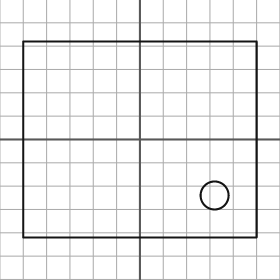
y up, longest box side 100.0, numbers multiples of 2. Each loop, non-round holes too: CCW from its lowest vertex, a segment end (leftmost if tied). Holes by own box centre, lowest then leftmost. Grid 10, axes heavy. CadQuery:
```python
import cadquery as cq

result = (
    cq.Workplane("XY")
    .moveTo(-50.0, -42.0)
    .lineTo(50.0, -42.0)
    .lineTo(50.0, 42.0)
    .lineTo(-50.0, 42.0)
    .close()
    .moveTo(32.0, -24.0)
    .circle(6.0)
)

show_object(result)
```